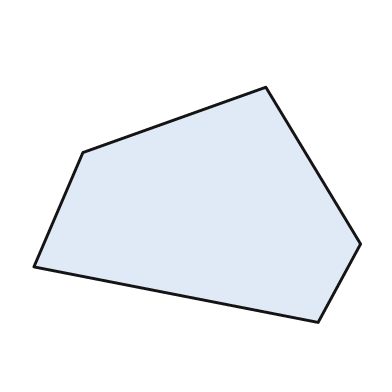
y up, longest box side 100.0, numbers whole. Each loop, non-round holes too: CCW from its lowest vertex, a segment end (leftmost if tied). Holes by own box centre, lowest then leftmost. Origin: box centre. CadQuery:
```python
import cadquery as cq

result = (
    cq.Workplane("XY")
    .moveTo(37.0, -36.0)
    .lineTo(50.0, -12.0)
    .lineTo(21.0, 36.0)
    .lineTo(-35.0, 16.0)
    .lineTo(-50.0, -19.0)
    .close()
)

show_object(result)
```